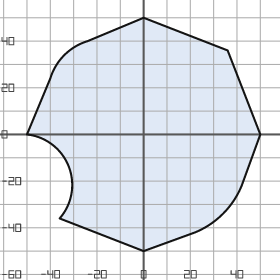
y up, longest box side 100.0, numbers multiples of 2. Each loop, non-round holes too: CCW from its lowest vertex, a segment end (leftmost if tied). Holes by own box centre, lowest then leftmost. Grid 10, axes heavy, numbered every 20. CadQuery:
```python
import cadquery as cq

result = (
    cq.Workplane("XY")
    .moveTo(0.0, -50.0)
    .lineTo(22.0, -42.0)
    .threePointArc((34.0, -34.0), (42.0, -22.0))
    .lineTo(50.0, 0.0)
    .lineTo(36.0, 36.0)
    .lineTo(0.0, 50.0)
    .lineTo(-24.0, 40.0)
    .threePointArc((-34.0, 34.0), (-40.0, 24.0))
    .lineTo(-50.0, 0.0)
    .threePointArc((-32.0, -14.0), (-36.0, -36.0))
    .close()
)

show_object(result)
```